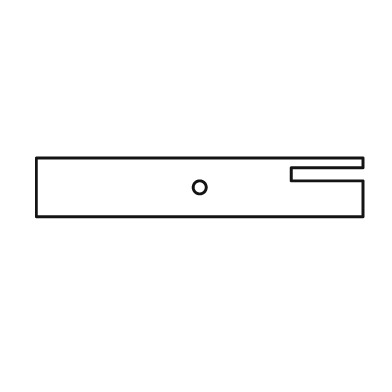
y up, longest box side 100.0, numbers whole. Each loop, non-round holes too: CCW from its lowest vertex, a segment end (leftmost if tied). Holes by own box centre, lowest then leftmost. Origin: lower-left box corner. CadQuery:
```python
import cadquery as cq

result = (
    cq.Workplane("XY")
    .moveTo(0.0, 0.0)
    .lineTo(100.0, 0.0)
    .lineTo(100.0, 11.0)
    .lineTo(78.0, 11.0)
    .lineTo(78.0, 15.0)
    .lineTo(100.0, 15.0)
    .lineTo(100.0, 18.0)
    .lineTo(0.0, 18.0)
    .close()
    .moveTo(50.0, 9.0)
    .circle(2.0)
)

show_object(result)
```